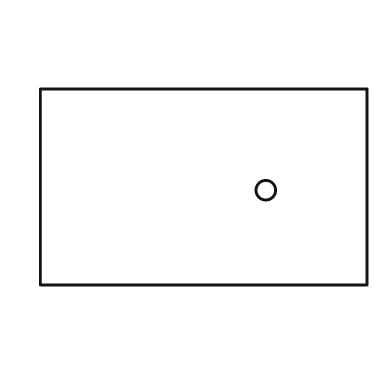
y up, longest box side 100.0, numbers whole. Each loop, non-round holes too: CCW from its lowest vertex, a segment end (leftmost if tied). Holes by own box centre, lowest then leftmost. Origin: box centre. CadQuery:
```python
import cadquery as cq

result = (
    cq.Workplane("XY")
    .moveTo(-50.0, -30.0)
    .lineTo(50.0, -30.0)
    .lineTo(50.0, 30.0)
    .lineTo(-50.0, 30.0)
    .close()
    .moveTo(19.0, -1.0)
    .circle(3.0)
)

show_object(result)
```